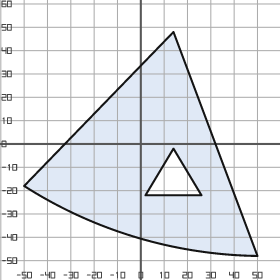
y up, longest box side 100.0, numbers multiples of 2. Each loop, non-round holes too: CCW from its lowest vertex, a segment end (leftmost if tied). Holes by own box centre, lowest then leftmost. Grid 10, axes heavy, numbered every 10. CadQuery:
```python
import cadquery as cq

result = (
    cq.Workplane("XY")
    .moveTo(50.0, -48.0)
    .lineTo(14.0, 48.0)
    .lineTo(-50.0, -18.0)
    .threePointArc((-2.0, -40.0), (50.0, -48.0))
    .close()
    .moveTo(2.0, -22.0)
    .lineTo(26.0, -22.0)
    .lineTo(14.0, -2.0)
    .close()
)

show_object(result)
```